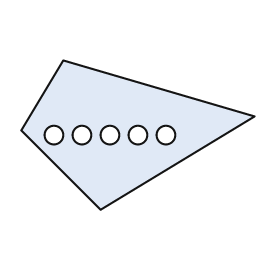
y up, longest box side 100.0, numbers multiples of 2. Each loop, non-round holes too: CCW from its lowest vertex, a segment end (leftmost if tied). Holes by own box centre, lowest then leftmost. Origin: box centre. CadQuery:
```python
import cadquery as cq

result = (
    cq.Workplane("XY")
    .moveTo(-16.0, -32.0)
    .lineTo(50.0, 8.0)
    .lineTo(-32.0, 32.0)
    .lineTo(-50.0, 2.0)
    .close()
    .moveTo(-36.0, 0.0)
    .circle(4.0)
    .moveTo(-24.0, 0.0)
    .circle(4.0)
    .moveTo(-12.0, 0.0)
    .circle(4.0)
    .moveTo(0.0, 0.0)
    .circle(4.0)
    .moveTo(12.0, 0.0)
    .circle(4.0)
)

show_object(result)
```